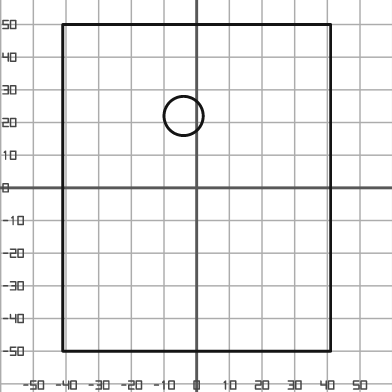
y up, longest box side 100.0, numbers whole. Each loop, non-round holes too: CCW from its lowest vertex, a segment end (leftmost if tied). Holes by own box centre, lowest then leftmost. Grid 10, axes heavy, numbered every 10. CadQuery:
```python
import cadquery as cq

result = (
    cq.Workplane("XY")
    .moveTo(-41.0, -50.0)
    .lineTo(41.0, -50.0)
    .lineTo(41.0, 50.0)
    .lineTo(-41.0, 50.0)
    .close()
    .moveTo(-4.0, 22.0)
    .circle(6.0)
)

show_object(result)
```